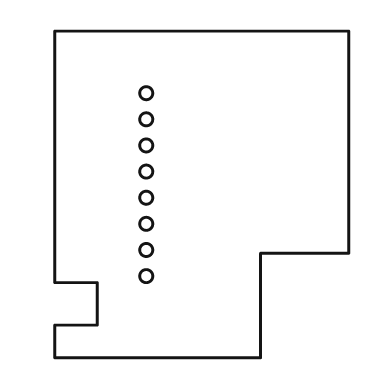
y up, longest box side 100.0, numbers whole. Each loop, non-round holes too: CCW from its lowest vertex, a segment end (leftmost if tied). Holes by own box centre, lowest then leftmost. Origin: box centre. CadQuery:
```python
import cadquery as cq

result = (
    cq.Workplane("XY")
    .moveTo(-45.0, -50.0)
    .lineTo(18.0, -50.0)
    .lineTo(18.0, -18.0)
    .lineTo(45.0, -18.0)
    .lineTo(45.0, 50.0)
    .lineTo(-45.0, 50.0)
    .lineTo(-45.0, -27.0)
    .lineTo(-32.0, -27.0)
    .lineTo(-32.0, -40.0)
    .lineTo(-45.0, -40.0)
    .close()
    .moveTo(-17.0, -25.0)
    .circle(2.0)
    .moveTo(-17.0, -17.0)
    .circle(2.0)
    .moveTo(-17.0, -9.0)
    .circle(2.0)
    .moveTo(-17.0, -1.0)
    .circle(2.0)
    .moveTo(-17.0, 7.0)
    .circle(2.0)
    .moveTo(-17.0, 15.0)
    .circle(2.0)
    .moveTo(-17.0, 23.0)
    .circle(2.0)
    .moveTo(-17.0, 31.0)
    .circle(2.0)
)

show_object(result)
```